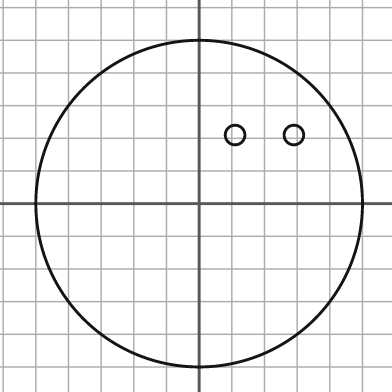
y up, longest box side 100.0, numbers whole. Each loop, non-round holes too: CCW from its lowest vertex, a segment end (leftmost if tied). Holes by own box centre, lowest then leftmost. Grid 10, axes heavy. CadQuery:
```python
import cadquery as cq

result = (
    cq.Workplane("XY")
    .moveTo(0.0, 0.0)
    .circle(50.0)
    .moveTo(11.0, 21.0)
    .circle(3.0)
    .moveTo(29.0, 21.0)
    .circle(3.0)
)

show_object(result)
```